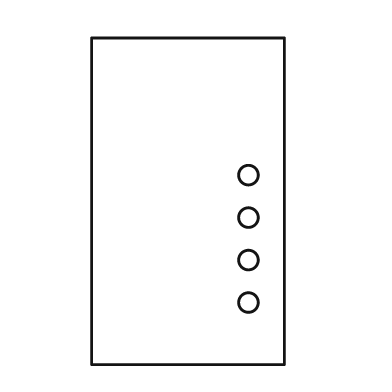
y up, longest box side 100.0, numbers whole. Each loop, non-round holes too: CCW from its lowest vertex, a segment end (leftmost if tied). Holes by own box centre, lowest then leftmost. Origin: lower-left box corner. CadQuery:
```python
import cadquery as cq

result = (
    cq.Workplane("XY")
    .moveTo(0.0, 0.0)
    .lineTo(59.0, 0.0)
    .lineTo(59.0, 100.0)
    .lineTo(0.0, 100.0)
    .close()
    .moveTo(48.0, 19.0)
    .circle(3.0)
    .moveTo(48.0, 32.0)
    .circle(3.0)
    .moveTo(48.0, 45.0)
    .circle(3.0)
    .moveTo(48.0, 58.0)
    .circle(3.0)
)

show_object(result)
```